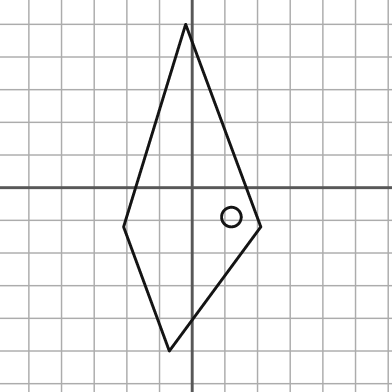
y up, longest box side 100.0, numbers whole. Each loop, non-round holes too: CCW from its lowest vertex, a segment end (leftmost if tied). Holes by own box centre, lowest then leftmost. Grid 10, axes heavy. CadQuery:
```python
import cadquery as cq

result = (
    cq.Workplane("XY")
    .moveTo(-7.0, -50.0)
    .lineTo(21.0, -12.0)
    .lineTo(-2.0, 50.0)
    .lineTo(-21.0, -12.0)
    .close()
    .moveTo(12.0, -9.0)
    .circle(3.0)
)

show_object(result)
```